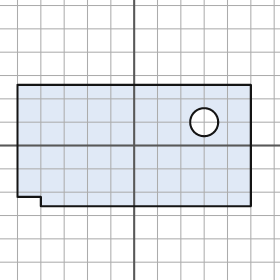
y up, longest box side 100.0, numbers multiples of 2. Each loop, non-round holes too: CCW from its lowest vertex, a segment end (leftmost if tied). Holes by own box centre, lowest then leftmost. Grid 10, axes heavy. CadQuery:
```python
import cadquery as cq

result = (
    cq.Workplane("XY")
    .moveTo(-40.0, -26.0)
    .lineTo(50.0, -26.0)
    .lineTo(50.0, 26.0)
    .lineTo(-50.0, 26.0)
    .lineTo(-50.0, -22.0)
    .lineTo(-40.0, -22.0)
    .close()
    .moveTo(30.0, 10.0)
    .circle(6.0)
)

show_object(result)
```